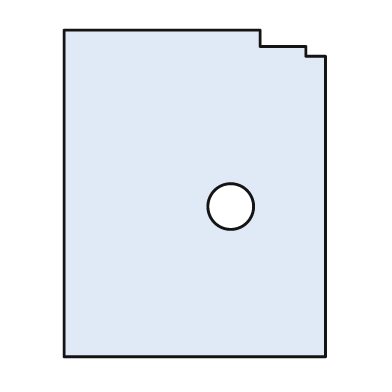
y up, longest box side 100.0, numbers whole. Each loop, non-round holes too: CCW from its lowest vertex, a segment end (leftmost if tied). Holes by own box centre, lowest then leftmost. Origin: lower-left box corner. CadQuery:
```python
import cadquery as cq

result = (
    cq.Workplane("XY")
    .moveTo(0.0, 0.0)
    .lineTo(80.0, 0.0)
    .lineTo(80.0, 92.0)
    .lineTo(74.0, 92.0)
    .lineTo(74.0, 95.0)
    .lineTo(60.0, 95.0)
    .lineTo(60.0, 100.0)
    .lineTo(0.0, 100.0)
    .close()
    .moveTo(51.0, 46.0)
    .circle(7.0)
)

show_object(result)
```